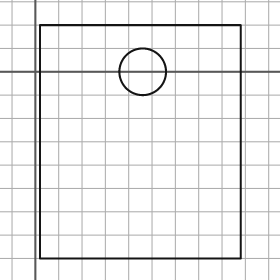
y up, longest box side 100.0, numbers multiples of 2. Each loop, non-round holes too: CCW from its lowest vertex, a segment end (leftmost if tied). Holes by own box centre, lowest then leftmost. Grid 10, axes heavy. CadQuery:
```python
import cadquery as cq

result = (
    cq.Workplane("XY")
    .moveTo(2.0, -80.0)
    .lineTo(88.0, -80.0)
    .lineTo(88.0, 20.0)
    .lineTo(2.0, 20.0)
    .close()
    .moveTo(46.0, 0.0)
    .circle(10.0)
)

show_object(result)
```